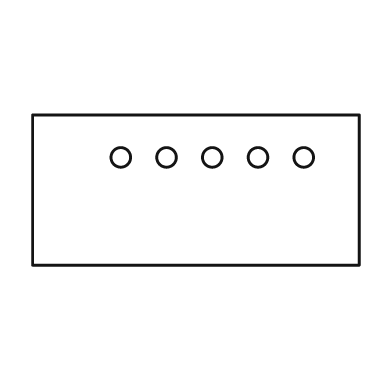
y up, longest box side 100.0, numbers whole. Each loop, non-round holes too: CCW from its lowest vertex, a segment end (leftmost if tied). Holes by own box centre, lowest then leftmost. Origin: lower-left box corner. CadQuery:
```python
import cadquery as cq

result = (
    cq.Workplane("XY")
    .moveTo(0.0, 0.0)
    .lineTo(100.0, 0.0)
    .lineTo(100.0, 46.0)
    .lineTo(0.0, 46.0)
    .close()
    .moveTo(27.0, 33.0)
    .circle(3.0)
    .moveTo(41.0, 33.0)
    .circle(3.0)
    .moveTo(55.0, 33.0)
    .circle(3.0)
    .moveTo(69.0, 33.0)
    .circle(3.0)
    .moveTo(83.0, 33.0)
    .circle(3.0)
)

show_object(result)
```